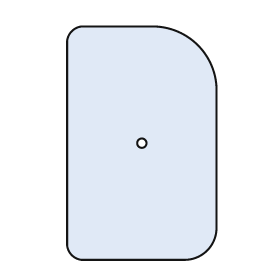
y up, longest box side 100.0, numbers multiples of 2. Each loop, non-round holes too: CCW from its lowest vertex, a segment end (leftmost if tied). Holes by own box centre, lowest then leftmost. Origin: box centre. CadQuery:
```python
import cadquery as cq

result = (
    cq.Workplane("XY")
    .moveTo(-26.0, -50.0)
    .lineTo(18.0, -50.0)
    .threePointArc((28.0, -46.0), (32.0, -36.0))
    .lineTo(32.0, 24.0)
    .threePointArc((24.0, 42.0), (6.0, 50.0))
    .lineTo(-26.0, 50.0)
    .threePointArc((-30.0, 48.0), (-32.0, 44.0))
    .lineTo(-32.0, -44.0)
    .threePointArc((-30.0, -48.0), (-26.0, -50.0))
    .close()
    .moveTo(0.0, 0.0)
    .circle(2.0)
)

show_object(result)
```